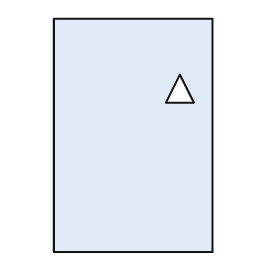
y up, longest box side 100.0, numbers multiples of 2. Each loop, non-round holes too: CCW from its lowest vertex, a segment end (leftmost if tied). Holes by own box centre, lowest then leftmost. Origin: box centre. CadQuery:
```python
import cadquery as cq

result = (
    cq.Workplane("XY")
    .moveTo(-34.0, -50.0)
    .lineTo(34.0, -50.0)
    .lineTo(34.0, 50.0)
    .lineTo(-34.0, 50.0)
    .close()
    .moveTo(14.0, 14.0)
    .lineTo(26.0, 14.0)
    .lineTo(20.0, 26.0)
    .close()
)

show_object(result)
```